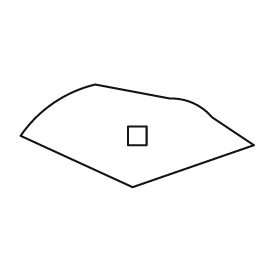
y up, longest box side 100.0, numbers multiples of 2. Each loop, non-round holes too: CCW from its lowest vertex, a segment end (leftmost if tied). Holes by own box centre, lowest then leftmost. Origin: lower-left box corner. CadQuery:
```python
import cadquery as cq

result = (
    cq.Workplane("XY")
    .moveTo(48.0, 0.0)
    .lineTo(100.0, 18.0)
    .lineTo(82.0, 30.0)
    .threePointArc((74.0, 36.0), (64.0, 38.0))
    .lineTo(32.0, 44.0)
    .threePointArc((14.0, 36.0), (0.0, 22.0))
    .close()
    .moveTo(46.0, 18.0)
    .lineTo(54.0, 18.0)
    .lineTo(54.0, 26.0)
    .lineTo(46.0, 26.0)
    .close()
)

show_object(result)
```